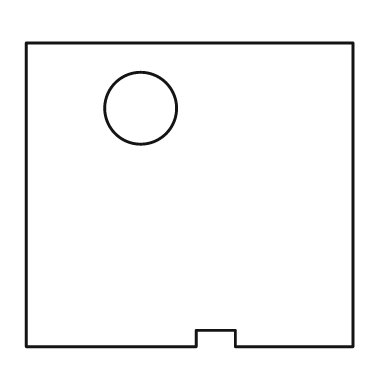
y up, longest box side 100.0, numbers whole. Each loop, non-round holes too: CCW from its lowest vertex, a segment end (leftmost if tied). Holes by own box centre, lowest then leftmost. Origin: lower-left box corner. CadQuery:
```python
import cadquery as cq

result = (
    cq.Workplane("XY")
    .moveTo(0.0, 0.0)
    .lineTo(52.0, 0.0)
    .lineTo(52.0, 5.0)
    .lineTo(64.0, 5.0)
    .lineTo(64.0, 0.0)
    .lineTo(100.0, 0.0)
    .lineTo(100.0, 93.0)
    .lineTo(0.0, 93.0)
    .close()
    .moveTo(35.0, 73.0)
    .circle(11.0)
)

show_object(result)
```